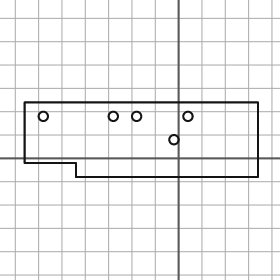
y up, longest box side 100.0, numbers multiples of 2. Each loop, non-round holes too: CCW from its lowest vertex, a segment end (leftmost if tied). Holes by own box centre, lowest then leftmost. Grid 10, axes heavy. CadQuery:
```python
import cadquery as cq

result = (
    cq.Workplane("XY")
    .moveTo(-44.0, -8.0)
    .lineTo(34.0, -8.0)
    .lineTo(34.0, 24.0)
    .lineTo(-66.0, 24.0)
    .lineTo(-66.0, -2.0)
    .lineTo(-44.0, -2.0)
    .close()
    .moveTo(-2.0, 8.0)
    .circle(2.0)
    .moveTo(-58.0, 18.0)
    .circle(2.0)
    .moveTo(-28.0, 18.0)
    .circle(2.0)
    .moveTo(-18.0, 18.0)
    .circle(2.0)
    .moveTo(4.0, 18.0)
    .circle(2.0)
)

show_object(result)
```